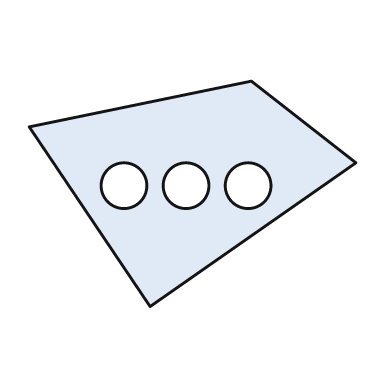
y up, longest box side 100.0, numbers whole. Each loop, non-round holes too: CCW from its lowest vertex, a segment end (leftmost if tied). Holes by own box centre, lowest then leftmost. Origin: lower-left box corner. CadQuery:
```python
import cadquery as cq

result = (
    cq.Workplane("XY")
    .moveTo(37.0, 0.0)
    .lineTo(100.0, 44.0)
    .lineTo(68.0, 69.0)
    .lineTo(0.0, 55.0)
    .close()
    .moveTo(29.0, 37.0)
    .circle(7.0)
    .moveTo(48.0, 37.0)
    .circle(7.0)
    .moveTo(67.0, 37.0)
    .circle(7.0)
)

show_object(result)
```